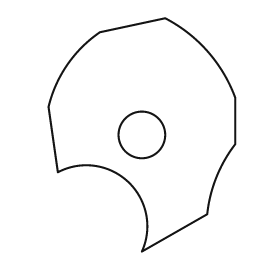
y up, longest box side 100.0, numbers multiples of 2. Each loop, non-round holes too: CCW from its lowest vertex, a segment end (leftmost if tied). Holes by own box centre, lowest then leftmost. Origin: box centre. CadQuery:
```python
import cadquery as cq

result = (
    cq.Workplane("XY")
    .moveTo(0.0, -50.0)
    .lineTo(28.0, -34.0)
    .threePointArc((32.0, -18.0), (40.0, -4.0))
    .lineTo(40.0, 16.0)
    .threePointArc((28.0, 36.0), (10.0, 50.0))
    .lineTo(-18.0, 44.0)
    .threePointArc((-32.0, 30.0), (-40.0, 12.0))
    .lineTo(-36.0, -16.0)
    .threePointArc((-6.0, -20.0), (0.0, -50.0))
    .close()
    .moveTo(0.0, 0.0)
    .circle(10.0)
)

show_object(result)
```